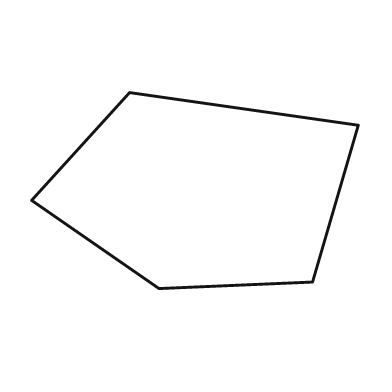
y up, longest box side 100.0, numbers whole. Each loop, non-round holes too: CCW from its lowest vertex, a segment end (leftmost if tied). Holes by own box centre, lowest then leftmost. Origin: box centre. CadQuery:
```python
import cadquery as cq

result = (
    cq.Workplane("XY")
    .moveTo(-11.0, -30.0)
    .lineTo(36.0, -28.0)
    .lineTo(50.0, 20.0)
    .lineTo(-20.0, 30.0)
    .lineTo(-50.0, -3.0)
    .close()
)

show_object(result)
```